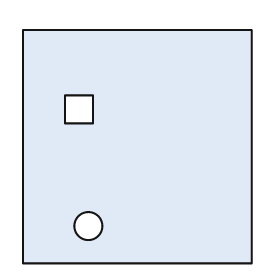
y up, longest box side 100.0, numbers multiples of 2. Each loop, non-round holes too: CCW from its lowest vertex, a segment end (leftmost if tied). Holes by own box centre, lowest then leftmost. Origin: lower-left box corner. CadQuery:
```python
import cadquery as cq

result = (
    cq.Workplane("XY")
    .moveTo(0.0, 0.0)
    .lineTo(98.0, 0.0)
    .lineTo(98.0, 100.0)
    .lineTo(0.0, 100.0)
    .close()
    .moveTo(28.0, 16.0)
    .circle(6.0)
    .moveTo(18.0, 60.0)
    .lineTo(30.0, 60.0)
    .lineTo(30.0, 72.0)
    .lineTo(18.0, 72.0)
    .close()
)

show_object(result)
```